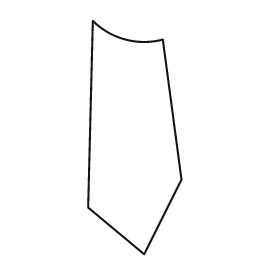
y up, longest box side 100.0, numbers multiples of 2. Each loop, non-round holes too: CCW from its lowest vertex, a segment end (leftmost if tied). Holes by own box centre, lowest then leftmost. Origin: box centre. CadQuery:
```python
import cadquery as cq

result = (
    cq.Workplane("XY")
    .moveTo(4.0, -50.0)
    .lineTo(20.0, -18.0)
    .lineTo(12.0, 42.0)
    .threePointArc((-4.0, 42.0), (-18.0, 50.0))
    .lineTo(-20.0, -30.0)
    .close()
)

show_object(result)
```